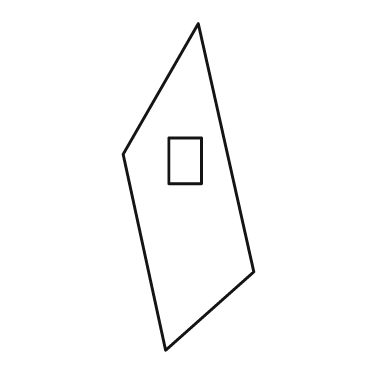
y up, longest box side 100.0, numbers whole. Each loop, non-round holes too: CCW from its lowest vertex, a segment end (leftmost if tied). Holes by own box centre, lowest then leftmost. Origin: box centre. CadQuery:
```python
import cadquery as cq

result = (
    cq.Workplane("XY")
    .moveTo(-7.0, -50.0)
    .lineTo(20.0, -26.0)
    .lineTo(3.0, 50.0)
    .lineTo(-20.0, 10.0)
    .close()
    .moveTo(-6.0, 1.0)
    .lineTo(4.0, 1.0)
    .lineTo(4.0, 15.0)
    .lineTo(-6.0, 15.0)
    .close()
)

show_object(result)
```